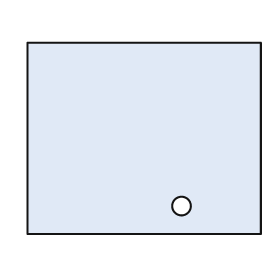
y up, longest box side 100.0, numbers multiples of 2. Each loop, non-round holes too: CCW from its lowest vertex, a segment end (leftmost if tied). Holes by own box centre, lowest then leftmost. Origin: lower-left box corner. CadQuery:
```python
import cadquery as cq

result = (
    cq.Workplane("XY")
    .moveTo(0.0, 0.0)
    .lineTo(100.0, 0.0)
    .lineTo(100.0, 82.0)
    .lineTo(0.0, 82.0)
    .close()
    .moveTo(66.0, 12.0)
    .circle(4.0)
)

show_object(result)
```